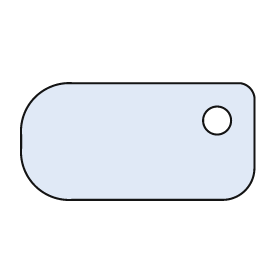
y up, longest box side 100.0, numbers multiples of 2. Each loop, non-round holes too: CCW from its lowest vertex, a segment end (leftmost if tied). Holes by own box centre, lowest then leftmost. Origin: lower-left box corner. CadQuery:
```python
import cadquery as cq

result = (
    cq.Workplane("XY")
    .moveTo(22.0, 0.0)
    .lineTo(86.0, 0.0)
    .threePointArc((96.0, 4.0), (100.0, 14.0))
    .lineTo(100.0, 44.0)
    .threePointArc((98.0, 48.0), (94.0, 50.0))
    .lineTo(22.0, 50.0)
    .threePointArc((6.0, 44.0), (0.0, 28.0))
    .lineTo(0.0, 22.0)
    .threePointArc((6.0, 6.0), (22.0, 0.0))
    .close()
    .moveTo(84.0, 34.0)
    .circle(6.0)
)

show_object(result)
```